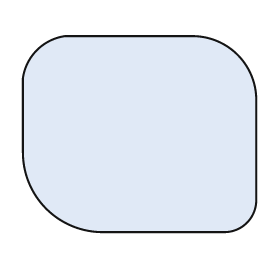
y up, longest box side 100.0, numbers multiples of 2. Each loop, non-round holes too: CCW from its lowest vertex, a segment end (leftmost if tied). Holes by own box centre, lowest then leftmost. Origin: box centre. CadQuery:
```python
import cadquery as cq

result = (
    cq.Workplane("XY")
    .moveTo(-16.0, -42.0)
    .lineTo(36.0, -42.0)
    .threePointArc((46.0, -38.0), (50.0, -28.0))
    .lineTo(50.0, 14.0)
    .threePointArc((42.0, 34.0), (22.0, 42.0))
    .lineTo(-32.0, 42.0)
    .threePointArc((-44.0, 36.0), (-50.0, 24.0))
    .lineTo(-50.0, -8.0)
    .threePointArc((-40.0, -32.0), (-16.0, -42.0))
    .close()
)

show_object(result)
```